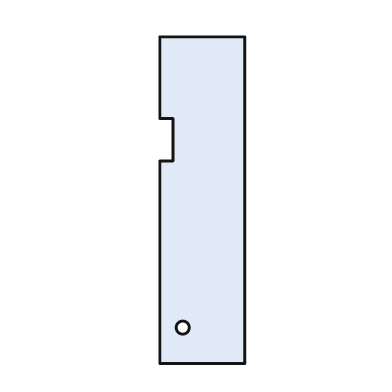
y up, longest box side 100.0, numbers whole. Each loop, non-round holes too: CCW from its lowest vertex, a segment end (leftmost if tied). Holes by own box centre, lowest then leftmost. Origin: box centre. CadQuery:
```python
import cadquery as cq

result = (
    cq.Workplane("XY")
    .moveTo(-13.0, -50.0)
    .lineTo(13.0, -50.0)
    .lineTo(13.0, 50.0)
    .lineTo(-13.0, 50.0)
    .lineTo(-13.0, 25.0)
    .lineTo(-9.0, 25.0)
    .lineTo(-9.0, 12.0)
    .lineTo(-13.0, 12.0)
    .close()
    .moveTo(-6.0, -39.0)
    .circle(2.0)
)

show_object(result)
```